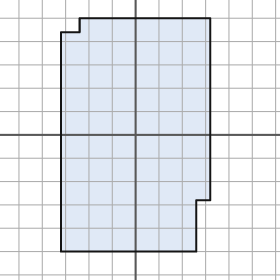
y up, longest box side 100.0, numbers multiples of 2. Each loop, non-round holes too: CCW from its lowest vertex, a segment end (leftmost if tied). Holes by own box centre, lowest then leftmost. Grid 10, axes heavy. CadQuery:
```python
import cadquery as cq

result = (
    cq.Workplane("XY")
    .moveTo(-32.0, -50.0)
    .lineTo(26.0, -50.0)
    .lineTo(26.0, -28.0)
    .lineTo(32.0, -28.0)
    .lineTo(32.0, 50.0)
    .lineTo(-24.0, 50.0)
    .lineTo(-24.0, 44.0)
    .lineTo(-32.0, 44.0)
    .close()
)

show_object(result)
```